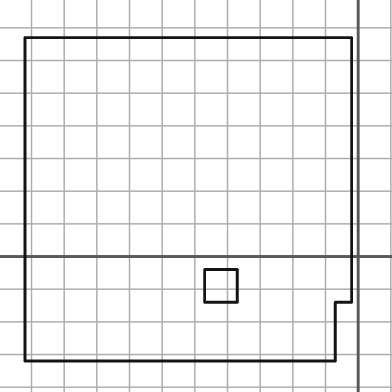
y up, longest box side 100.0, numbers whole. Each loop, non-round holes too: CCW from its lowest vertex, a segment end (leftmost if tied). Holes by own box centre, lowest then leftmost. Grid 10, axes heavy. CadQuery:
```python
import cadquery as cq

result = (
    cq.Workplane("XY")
    .moveTo(-102.0, -32.0)
    .lineTo(-7.0, -32.0)
    .lineTo(-7.0, -14.0)
    .lineTo(-2.0, -14.0)
    .lineTo(-2.0, 67.0)
    .lineTo(-102.0, 67.0)
    .close()
    .moveTo(-47.0, -14.0)
    .lineTo(-37.0, -14.0)
    .lineTo(-37.0, -4.0)
    .lineTo(-47.0, -4.0)
    .close()
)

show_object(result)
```